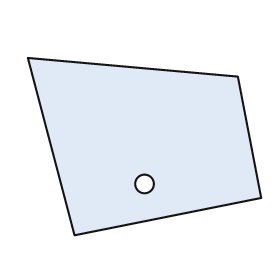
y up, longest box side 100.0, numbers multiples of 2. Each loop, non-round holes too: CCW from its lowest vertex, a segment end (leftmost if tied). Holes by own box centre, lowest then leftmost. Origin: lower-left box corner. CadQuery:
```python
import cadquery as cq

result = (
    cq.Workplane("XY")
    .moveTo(20.0, 0.0)
    .lineTo(100.0, 16.0)
    .lineTo(90.0, 68.0)
    .lineTo(0.0, 76.0)
    .close()
    .moveTo(50.0, 22.0)
    .circle(4.0)
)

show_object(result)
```